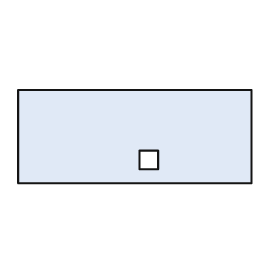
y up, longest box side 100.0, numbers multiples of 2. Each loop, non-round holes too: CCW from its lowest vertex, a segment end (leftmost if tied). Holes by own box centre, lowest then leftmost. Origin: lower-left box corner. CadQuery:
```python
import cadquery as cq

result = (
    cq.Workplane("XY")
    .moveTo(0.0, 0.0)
    .lineTo(100.0, 0.0)
    .lineTo(100.0, 40.0)
    .lineTo(0.0, 40.0)
    .close()
    .moveTo(52.0, 6.0)
    .lineTo(60.0, 6.0)
    .lineTo(60.0, 14.0)
    .lineTo(52.0, 14.0)
    .close()
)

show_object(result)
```